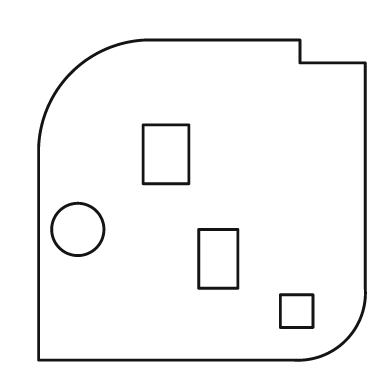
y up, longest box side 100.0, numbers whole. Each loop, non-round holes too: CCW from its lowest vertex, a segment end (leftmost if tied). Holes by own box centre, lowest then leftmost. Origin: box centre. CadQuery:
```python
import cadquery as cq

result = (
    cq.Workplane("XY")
    .moveTo(-50.0, -49.0)
    .lineTo(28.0, -49.0)
    .threePointArc((44.0, -43.0), (50.0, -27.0))
    .lineTo(50.0, 42.0)
    .lineTo(30.0, 42.0)
    .lineTo(30.0, 49.0)
    .lineTo(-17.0, 49.0)
    .threePointArc((-40.0, 39.0), (-50.0, 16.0))
    .close()
    .moveTo(24.0, -39.0)
    .lineTo(34.0, -39.0)
    .lineTo(34.0, -29.0)
    .lineTo(24.0, -29.0)
    .close()
    .moveTo(-1.0, -27.0)
    .lineTo(11.0, -27.0)
    .lineTo(11.0, -9.0)
    .lineTo(-1.0, -9.0)
    .close()
    .moveTo(-38.0, -9.0)
    .circle(8.0)
    .moveTo(-18.0, 5.0)
    .lineTo(-4.0, 5.0)
    .lineTo(-4.0, 23.0)
    .lineTo(-18.0, 23.0)
    .close()
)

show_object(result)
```